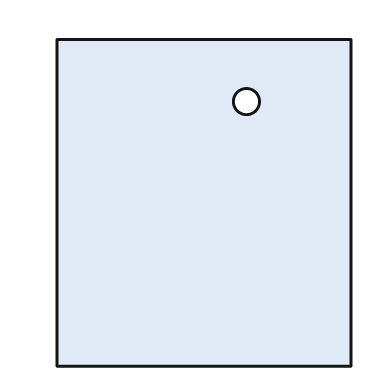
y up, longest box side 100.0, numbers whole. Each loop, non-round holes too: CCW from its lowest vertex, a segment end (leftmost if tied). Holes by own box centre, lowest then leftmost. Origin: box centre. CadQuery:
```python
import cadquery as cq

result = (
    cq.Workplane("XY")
    .moveTo(-45.0, -50.0)
    .lineTo(45.0, -50.0)
    .lineTo(45.0, 50.0)
    .lineTo(-45.0, 50.0)
    .close()
    .moveTo(13.0, 31.0)
    .circle(4.0)
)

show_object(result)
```